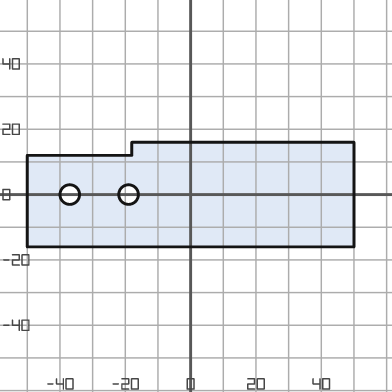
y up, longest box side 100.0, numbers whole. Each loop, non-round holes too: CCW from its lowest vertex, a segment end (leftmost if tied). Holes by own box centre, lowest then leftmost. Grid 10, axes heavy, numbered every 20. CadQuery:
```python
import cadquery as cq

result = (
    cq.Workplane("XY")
    .moveTo(-50.0, -16.0)
    .lineTo(50.0, -16.0)
    .lineTo(50.0, 16.0)
    .lineTo(-18.0, 16.0)
    .lineTo(-18.0, 12.0)
    .lineTo(-50.0, 12.0)
    .close()
    .moveTo(-37.0, 0.0)
    .circle(3.0)
    .moveTo(-19.0, 0.0)
    .circle(3.0)
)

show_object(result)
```